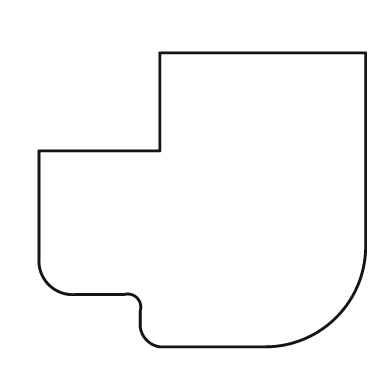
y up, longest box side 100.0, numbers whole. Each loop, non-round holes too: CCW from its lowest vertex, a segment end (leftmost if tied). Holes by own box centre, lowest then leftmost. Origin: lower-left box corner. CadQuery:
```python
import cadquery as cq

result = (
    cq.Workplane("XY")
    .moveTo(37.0, 0.0)
    .lineTo(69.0, 0.0)
    .threePointArc((91.0, 9.0), (100.0, 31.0))
    .lineTo(100.0, 90.0)
    .lineTo(37.0, 90.0)
    .lineTo(37.0, 60.0)
    .lineTo(0.0, 60.0)
    .lineTo(0.0, 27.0)
    .threePointArc((3.0, 19.0), (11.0, 16.0))
    .lineTo(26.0, 16.0)
    .threePointArc((30.0, 15.0), (31.0, 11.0))
    .lineTo(31.0, 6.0)
    .threePointArc((33.0, 2.0), (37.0, 0.0))
    .close()
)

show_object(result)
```